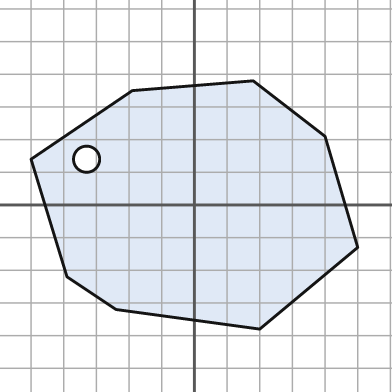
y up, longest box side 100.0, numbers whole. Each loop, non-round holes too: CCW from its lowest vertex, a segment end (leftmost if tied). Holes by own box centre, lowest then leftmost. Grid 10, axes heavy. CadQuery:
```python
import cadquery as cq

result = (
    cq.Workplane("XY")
    .moveTo(20.0, -38.0)
    .lineTo(50.0, -13.0)
    .lineTo(40.0, 21.0)
    .lineTo(18.0, 38.0)
    .lineTo(-19.0, 35.0)
    .lineTo(-50.0, 14.0)
    .lineTo(-39.0, -22.0)
    .lineTo(-24.0, -32.0)
    .close()
    .moveTo(-33.0, 14.0)
    .circle(4.0)
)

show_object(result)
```